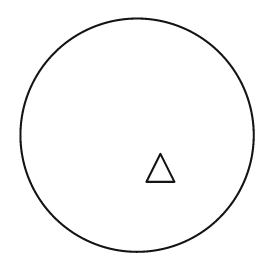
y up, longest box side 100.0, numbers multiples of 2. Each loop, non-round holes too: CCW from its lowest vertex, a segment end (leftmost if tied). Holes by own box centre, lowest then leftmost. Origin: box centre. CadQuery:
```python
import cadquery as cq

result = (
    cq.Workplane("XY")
    .moveTo(0.0, 0.0)
    .circle(50.0)
    .moveTo(4.0, -20.0)
    .lineTo(16.0, -20.0)
    .lineTo(10.0, -8.0)
    .close()
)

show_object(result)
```